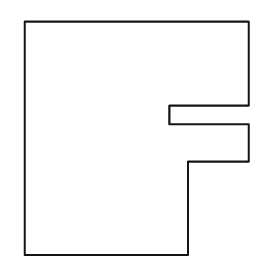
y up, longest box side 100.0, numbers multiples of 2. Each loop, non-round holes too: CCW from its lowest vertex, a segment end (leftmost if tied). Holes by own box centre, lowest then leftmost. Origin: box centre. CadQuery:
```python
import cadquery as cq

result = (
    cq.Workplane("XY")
    .moveTo(-48.0, -50.0)
    .lineTo(22.0, -50.0)
    .lineTo(22.0, -10.0)
    .lineTo(48.0, -10.0)
    .lineTo(48.0, 6.0)
    .lineTo(14.0, 6.0)
    .lineTo(14.0, 14.0)
    .lineTo(48.0, 14.0)
    .lineTo(48.0, 50.0)
    .lineTo(-48.0, 50.0)
    .close()
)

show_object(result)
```